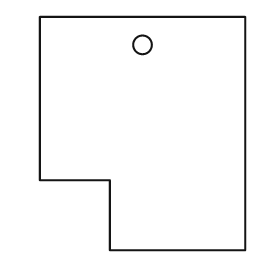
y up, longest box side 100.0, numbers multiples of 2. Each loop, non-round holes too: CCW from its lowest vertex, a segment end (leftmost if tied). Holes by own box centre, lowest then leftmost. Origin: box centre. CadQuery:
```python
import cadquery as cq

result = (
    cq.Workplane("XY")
    .moveTo(-14.0, -50.0)
    .lineTo(44.0, -50.0)
    .lineTo(44.0, 50.0)
    .lineTo(-44.0, 50.0)
    .lineTo(-44.0, -20.0)
    .lineTo(-14.0, -20.0)
    .close()
    .moveTo(0.0, 38.0)
    .circle(4.0)
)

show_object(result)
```